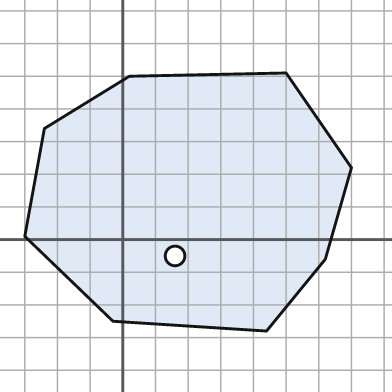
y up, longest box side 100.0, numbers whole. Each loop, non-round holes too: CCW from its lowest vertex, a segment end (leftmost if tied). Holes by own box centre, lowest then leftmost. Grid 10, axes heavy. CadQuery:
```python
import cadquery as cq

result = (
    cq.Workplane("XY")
    .moveTo(44.0, -28.0)
    .lineTo(62.0, -6.0)
    .lineTo(70.0, 22.0)
    .lineTo(50.0, 51.0)
    .lineTo(2.0, 50.0)
    .lineTo(-24.0, 34.0)
    .lineTo(-30.0, 1.0)
    .lineTo(-3.0, -25.0)
    .close()
    .moveTo(16.0, -5.0)
    .circle(3.0)
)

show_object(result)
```